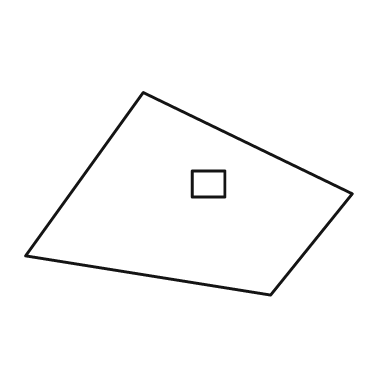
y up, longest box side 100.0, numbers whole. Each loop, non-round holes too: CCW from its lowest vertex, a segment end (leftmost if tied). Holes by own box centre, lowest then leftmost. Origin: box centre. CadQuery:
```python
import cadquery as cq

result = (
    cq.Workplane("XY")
    .moveTo(25.0, -31.0)
    .lineTo(50.0, 0.0)
    .lineTo(-14.0, 31.0)
    .lineTo(-50.0, -19.0)
    .close()
    .moveTo(1.0, -1.0)
    .lineTo(11.0, -1.0)
    .lineTo(11.0, 7.0)
    .lineTo(1.0, 7.0)
    .close()
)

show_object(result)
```